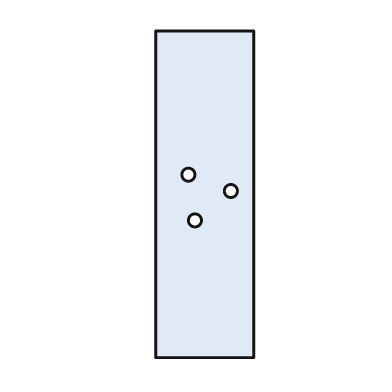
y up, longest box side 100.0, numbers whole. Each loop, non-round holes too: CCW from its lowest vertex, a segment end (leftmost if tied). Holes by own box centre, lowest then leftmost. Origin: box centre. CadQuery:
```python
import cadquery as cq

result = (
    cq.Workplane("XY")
    .moveTo(-15.0, -50.0)
    .lineTo(15.0, -50.0)
    .lineTo(15.0, 50.0)
    .lineTo(-15.0, 50.0)
    .close()
    .moveTo(-3.0, -8.0)
    .circle(2.0)
    .moveTo(8.0, 1.0)
    .circle(2.0)
    .moveTo(-5.0, 6.0)
    .circle(2.0)
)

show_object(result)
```